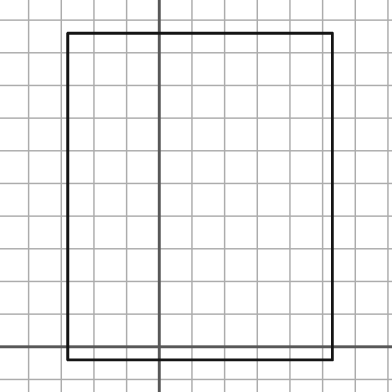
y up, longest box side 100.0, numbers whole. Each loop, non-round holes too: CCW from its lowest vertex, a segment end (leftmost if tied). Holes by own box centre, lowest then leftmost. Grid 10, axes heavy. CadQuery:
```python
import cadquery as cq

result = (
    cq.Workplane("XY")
    .moveTo(-28.0, -4.0)
    .lineTo(53.0, -4.0)
    .lineTo(53.0, 96.0)
    .lineTo(-28.0, 96.0)
    .close()
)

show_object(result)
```